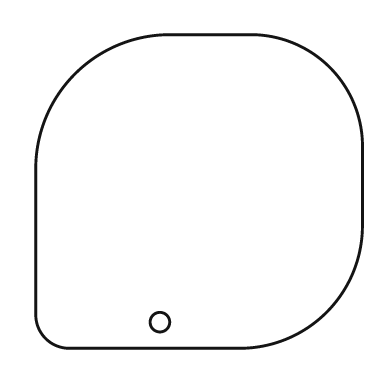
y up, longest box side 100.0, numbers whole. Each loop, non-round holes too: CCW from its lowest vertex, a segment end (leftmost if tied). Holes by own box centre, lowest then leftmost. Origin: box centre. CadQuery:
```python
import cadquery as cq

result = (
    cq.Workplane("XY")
    .moveTo(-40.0, -48.0)
    .lineTo(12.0, -48.0)
    .threePointArc((39.0, -37.0), (50.0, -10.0))
    .lineTo(50.0, 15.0)
    .threePointArc((40.0, 38.0), (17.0, 48.0))
    .lineTo(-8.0, 48.0)
    .threePointArc((-38.0, 36.0), (-50.0, 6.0))
    .lineTo(-50.0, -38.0)
    .threePointArc((-47.0, -45.0), (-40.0, -48.0))
    .close()
    .moveTo(-12.0, -40.0)
    .circle(3.0)
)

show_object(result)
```